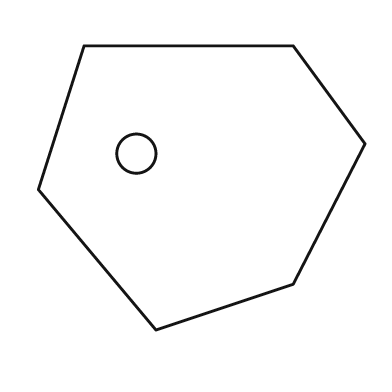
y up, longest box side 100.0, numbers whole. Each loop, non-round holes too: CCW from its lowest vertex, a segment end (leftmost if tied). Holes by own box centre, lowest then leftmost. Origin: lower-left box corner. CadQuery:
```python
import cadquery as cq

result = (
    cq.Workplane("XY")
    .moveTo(36.0, 0.0)
    .lineTo(78.0, 14.0)
    .lineTo(100.0, 57.0)
    .lineTo(78.0, 87.0)
    .lineTo(14.0, 87.0)
    .lineTo(0.0, 43.0)
    .close()
    .moveTo(30.0, 54.0)
    .circle(6.0)
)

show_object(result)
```